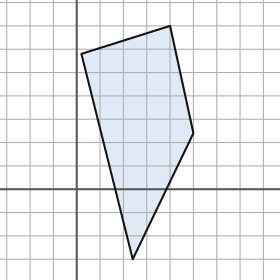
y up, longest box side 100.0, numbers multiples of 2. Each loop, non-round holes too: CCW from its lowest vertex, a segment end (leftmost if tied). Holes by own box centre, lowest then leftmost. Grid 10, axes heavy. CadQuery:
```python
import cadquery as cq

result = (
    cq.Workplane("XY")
    .moveTo(24.0, -30.0)
    .lineTo(50.0, 24.0)
    .lineTo(40.0, 70.0)
    .lineTo(2.0, 58.0)
    .close()
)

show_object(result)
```